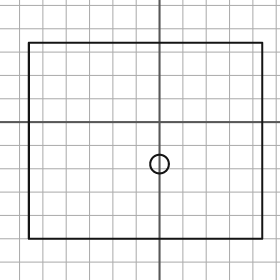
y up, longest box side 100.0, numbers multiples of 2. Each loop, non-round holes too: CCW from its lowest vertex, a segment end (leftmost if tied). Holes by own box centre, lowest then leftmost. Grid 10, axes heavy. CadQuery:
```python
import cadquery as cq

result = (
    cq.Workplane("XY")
    .moveTo(-56.0, -50.0)
    .lineTo(44.0, -50.0)
    .lineTo(44.0, 34.0)
    .lineTo(-56.0, 34.0)
    .close()
    .moveTo(0.0, -18.0)
    .circle(4.0)
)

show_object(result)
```